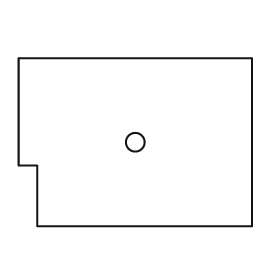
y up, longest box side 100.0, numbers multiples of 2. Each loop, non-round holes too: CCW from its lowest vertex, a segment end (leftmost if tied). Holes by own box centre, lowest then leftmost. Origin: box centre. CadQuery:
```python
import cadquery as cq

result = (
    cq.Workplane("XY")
    .moveTo(-42.0, -36.0)
    .lineTo(50.0, -36.0)
    .lineTo(50.0, 36.0)
    .lineTo(-50.0, 36.0)
    .lineTo(-50.0, -10.0)
    .lineTo(-42.0, -10.0)
    .close()
    .moveTo(0.0, 0.0)
    .circle(4.0)
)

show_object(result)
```